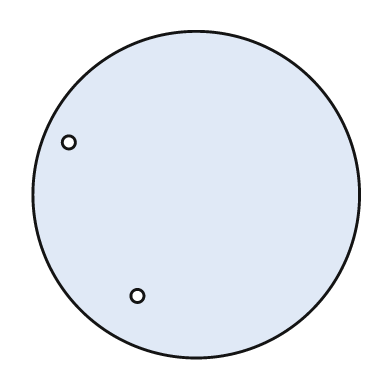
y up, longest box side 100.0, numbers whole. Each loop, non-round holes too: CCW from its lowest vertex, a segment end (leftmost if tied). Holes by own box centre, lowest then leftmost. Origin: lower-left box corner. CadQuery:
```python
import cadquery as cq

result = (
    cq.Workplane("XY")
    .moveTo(50.0, 50.0)
    .circle(50.0)
    .moveTo(32.0, 19.0)
    .circle(2.0)
    .moveTo(11.0, 66.0)
    .circle(2.0)
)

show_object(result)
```